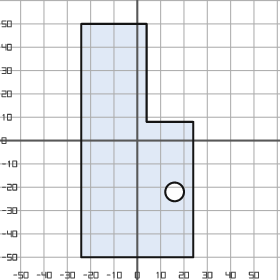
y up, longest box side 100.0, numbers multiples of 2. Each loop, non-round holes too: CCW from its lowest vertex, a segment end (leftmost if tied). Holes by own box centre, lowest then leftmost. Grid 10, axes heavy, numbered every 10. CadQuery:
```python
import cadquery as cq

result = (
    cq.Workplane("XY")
    .moveTo(-24.0, -50.0)
    .lineTo(24.0, -50.0)
    .lineTo(24.0, 8.0)
    .lineTo(4.0, 8.0)
    .lineTo(4.0, 50.0)
    .lineTo(-24.0, 50.0)
    .close()
    .moveTo(16.0, -22.0)
    .circle(4.0)
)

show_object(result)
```